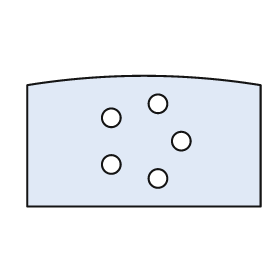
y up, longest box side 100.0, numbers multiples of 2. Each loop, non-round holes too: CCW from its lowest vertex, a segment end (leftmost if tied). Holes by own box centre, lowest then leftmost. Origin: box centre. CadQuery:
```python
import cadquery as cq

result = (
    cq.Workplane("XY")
    .moveTo(-50.0, -28.0)
    .lineTo(50.0, -28.0)
    .lineTo(50.0, 24.0)
    .threePointArc((0.0, 28.0), (-50.0, 24.0))
    .close()
    .moveTo(6.0, -16.0)
    .circle(4.0)
    .moveTo(-14.0, -10.0)
    .circle(4.0)
    .moveTo(16.0, 0.0)
    .circle(4.0)
    .moveTo(-14.0, 10.0)
    .circle(4.0)
    .moveTo(6.0, 16.0)
    .circle(4.0)
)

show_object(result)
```